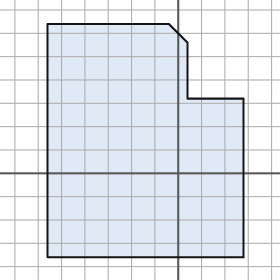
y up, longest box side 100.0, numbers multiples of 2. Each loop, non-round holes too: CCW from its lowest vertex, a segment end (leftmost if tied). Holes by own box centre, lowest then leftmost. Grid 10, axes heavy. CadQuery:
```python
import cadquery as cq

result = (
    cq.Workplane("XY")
    .moveTo(-56.0, -36.0)
    .lineTo(28.0, -36.0)
    .lineTo(28.0, 32.0)
    .lineTo(4.0, 32.0)
    .lineTo(4.0, 56.0)
    .lineTo(-4.0, 64.0)
    .lineTo(-56.0, 64.0)
    .close()
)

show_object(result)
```